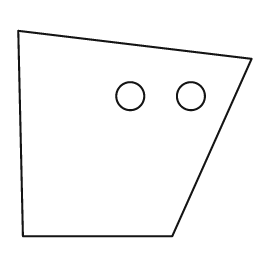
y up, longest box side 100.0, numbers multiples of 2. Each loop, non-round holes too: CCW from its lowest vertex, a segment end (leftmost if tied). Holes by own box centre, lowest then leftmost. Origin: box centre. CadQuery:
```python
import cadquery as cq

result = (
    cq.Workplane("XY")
    .moveTo(-48.0, -44.0)
    .lineTo(16.0, -44.0)
    .lineTo(50.0, 32.0)
    .lineTo(-50.0, 44.0)
    .close()
    .moveTo(-2.0, 16.0)
    .circle(6.0)
    .moveTo(24.0, 16.0)
    .circle(6.0)
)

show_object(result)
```